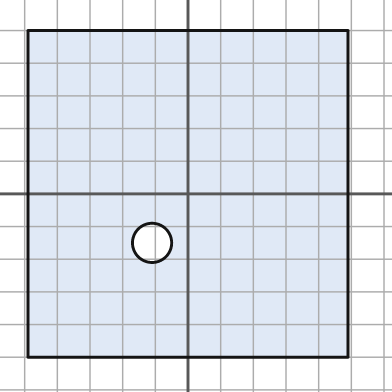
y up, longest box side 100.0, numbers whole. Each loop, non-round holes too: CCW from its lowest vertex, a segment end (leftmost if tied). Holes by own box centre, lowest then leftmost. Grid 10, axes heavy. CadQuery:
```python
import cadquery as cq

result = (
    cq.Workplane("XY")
    .moveTo(-49.0, -50.0)
    .lineTo(49.0, -50.0)
    .lineTo(49.0, 50.0)
    .lineTo(-49.0, 50.0)
    .close()
    .moveTo(-11.0, -15.0)
    .circle(6.0)
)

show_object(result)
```